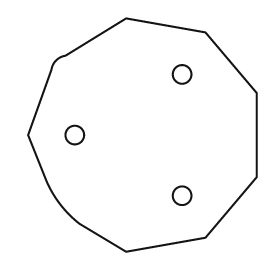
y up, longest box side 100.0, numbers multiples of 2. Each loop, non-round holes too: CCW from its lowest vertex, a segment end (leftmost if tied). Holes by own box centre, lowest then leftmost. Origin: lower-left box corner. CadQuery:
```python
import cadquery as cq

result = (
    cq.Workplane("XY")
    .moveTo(42.0, 0.0)
    .lineTo(76.0, 6.0)
    .lineTo(98.0, 32.0)
    .lineTo(98.0, 68.0)
    .lineTo(76.0, 94.0)
    .lineTo(42.0, 100.0)
    .lineTo(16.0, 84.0)
    .threePointArc((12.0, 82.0), (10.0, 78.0))
    .lineTo(0.0, 50.0)
    .lineTo(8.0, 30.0)
    .threePointArc((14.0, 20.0), (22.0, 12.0))
    .close()
    .moveTo(66.0, 24.0)
    .circle(4.0)
    .moveTo(20.0, 50.0)
    .circle(4.0)
    .moveTo(66.0, 76.0)
    .circle(4.0)
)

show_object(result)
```